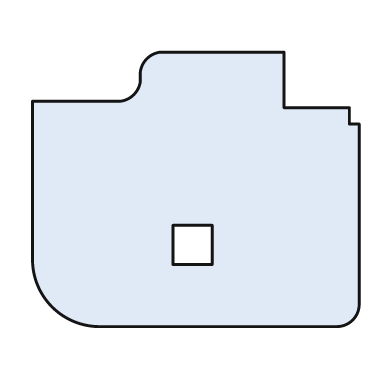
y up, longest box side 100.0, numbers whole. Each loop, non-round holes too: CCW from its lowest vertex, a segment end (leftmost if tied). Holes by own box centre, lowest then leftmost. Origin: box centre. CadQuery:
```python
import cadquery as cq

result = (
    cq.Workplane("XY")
    .moveTo(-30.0, -42.0)
    .lineTo(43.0, -42.0)
    .threePointArc((48.0, -40.0), (50.0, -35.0))
    .lineTo(50.0, 20.0)
    .lineTo(47.0, 20.0)
    .lineTo(47.0, 25.0)
    .lineTo(27.0, 25.0)
    .lineTo(27.0, 42.0)
    .lineTo(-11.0, 42.0)
    .threePointArc((-15.0, 40.0), (-17.0, 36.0))
    .lineTo(-17.0, 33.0)
    .threePointArc((-19.0, 29.0), (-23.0, 27.0))
    .lineTo(-50.0, 27.0)
    .lineTo(-50.0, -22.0)
    .threePointArc((-44.0, -36.0), (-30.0, -42.0))
    .close()
    .moveTo(-7.0, -23.0)
    .lineTo(5.0, -23.0)
    .lineTo(5.0, -11.0)
    .lineTo(-7.0, -11.0)
    .close()
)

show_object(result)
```